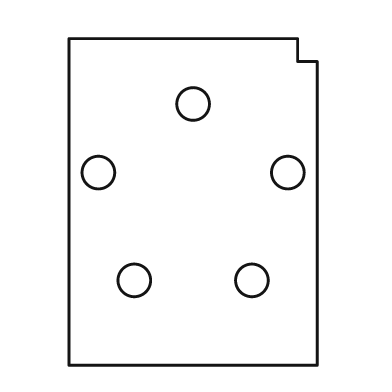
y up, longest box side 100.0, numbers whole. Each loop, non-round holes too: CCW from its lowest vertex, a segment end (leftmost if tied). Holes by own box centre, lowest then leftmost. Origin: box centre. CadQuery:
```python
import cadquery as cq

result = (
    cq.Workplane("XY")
    .moveTo(-38.0, -50.0)
    .lineTo(38.0, -50.0)
    .lineTo(38.0, 43.0)
    .lineTo(32.0, 43.0)
    .lineTo(32.0, 50.0)
    .lineTo(-38.0, 50.0)
    .close()
    .moveTo(-18.0, -24.0)
    .circle(5.0)
    .moveTo(18.0, -24.0)
    .circle(5.0)
    .moveTo(-29.0, 9.0)
    .circle(5.0)
    .moveTo(29.0, 9.0)
    .circle(5.0)
    .moveTo(0.0, 30.0)
    .circle(5.0)
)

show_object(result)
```